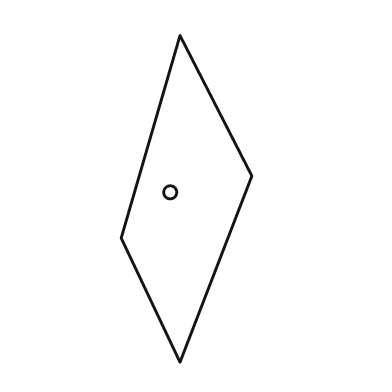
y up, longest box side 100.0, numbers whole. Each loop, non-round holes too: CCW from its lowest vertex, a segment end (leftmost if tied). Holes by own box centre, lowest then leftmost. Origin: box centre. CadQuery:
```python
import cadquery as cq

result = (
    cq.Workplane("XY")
    .moveTo(-2.0, -50.0)
    .lineTo(20.0, 7.0)
    .lineTo(-2.0, 50.0)
    .lineTo(-20.0, -12.0)
    .close()
    .moveTo(-5.0, 2.0)
    .circle(2.0)
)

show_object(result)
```